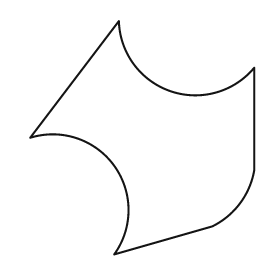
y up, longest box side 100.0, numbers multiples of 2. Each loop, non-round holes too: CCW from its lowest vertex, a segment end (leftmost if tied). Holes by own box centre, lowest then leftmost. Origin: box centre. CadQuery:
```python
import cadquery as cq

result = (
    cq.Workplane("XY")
    .moveTo(-12.0, -50.0)
    .lineTo(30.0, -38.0)
    .threePointArc((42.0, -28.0), (48.0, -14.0))
    .lineTo(48.0, 30.0)
    .threePointArc((12.0, 20.0), (-10.0, 50.0))
    .lineTo(-48.0, 0.0)
    .threePointArc((-12.0, -12.0), (-12.0, -50.0))
    .close()
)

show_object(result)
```